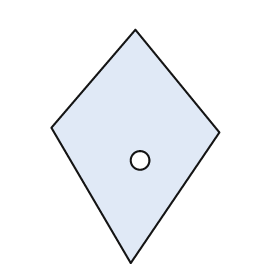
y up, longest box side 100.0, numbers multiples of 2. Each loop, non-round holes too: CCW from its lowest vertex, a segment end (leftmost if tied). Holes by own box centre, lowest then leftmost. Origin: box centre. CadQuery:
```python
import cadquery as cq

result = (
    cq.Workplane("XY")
    .moveTo(-2.0, -50.0)
    .lineTo(36.0, 6.0)
    .lineTo(0.0, 50.0)
    .lineTo(-36.0, 8.0)
    .close()
    .moveTo(2.0, -6.0)
    .circle(4.0)
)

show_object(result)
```